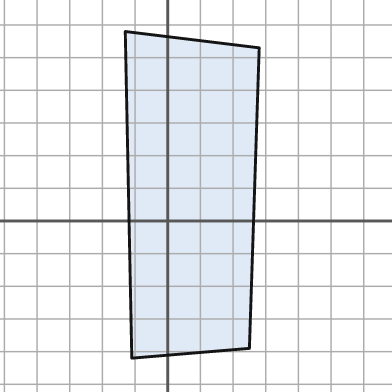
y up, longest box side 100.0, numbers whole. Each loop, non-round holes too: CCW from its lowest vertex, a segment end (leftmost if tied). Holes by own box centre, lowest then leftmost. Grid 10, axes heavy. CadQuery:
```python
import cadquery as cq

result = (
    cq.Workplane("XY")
    .moveTo(-11.0, -42.0)
    .lineTo(25.0, -39.0)
    .lineTo(28.0, 53.0)
    .lineTo(-13.0, 58.0)
    .close()
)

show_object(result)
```